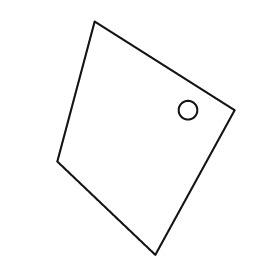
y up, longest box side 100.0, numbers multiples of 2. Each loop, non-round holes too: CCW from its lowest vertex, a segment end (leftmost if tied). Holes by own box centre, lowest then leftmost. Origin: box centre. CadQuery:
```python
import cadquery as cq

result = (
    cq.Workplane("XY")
    .moveTo(4.0, -50.0)
    .lineTo(38.0, 12.0)
    .lineTo(-22.0, 50.0)
    .lineTo(-38.0, -10.0)
    .close()
    .moveTo(18.0, 12.0)
    .circle(4.0)
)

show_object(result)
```